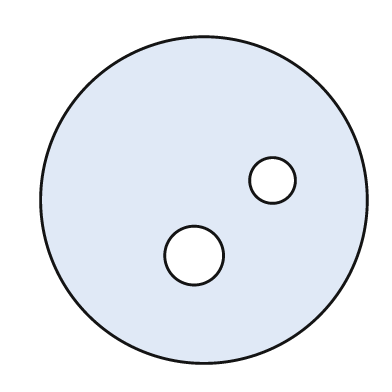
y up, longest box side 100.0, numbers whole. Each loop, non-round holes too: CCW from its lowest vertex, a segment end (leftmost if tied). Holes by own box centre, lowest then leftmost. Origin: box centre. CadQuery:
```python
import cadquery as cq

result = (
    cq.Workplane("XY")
    .moveTo(0.0, 0.0)
    .circle(50.0)
    .moveTo(-3.0, -17.0)
    .circle(9.0)
    .moveTo(21.0, 6.0)
    .circle(7.0)
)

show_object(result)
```